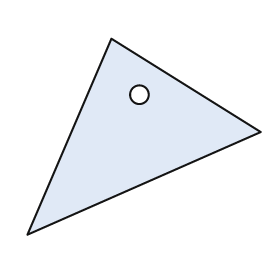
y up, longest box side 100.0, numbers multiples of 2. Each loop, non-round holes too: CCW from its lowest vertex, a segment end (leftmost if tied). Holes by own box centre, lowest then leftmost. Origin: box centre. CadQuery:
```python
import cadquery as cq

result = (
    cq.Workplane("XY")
    .moveTo(-50.0, -42.0)
    .lineTo(50.0, 2.0)
    .lineTo(-14.0, 42.0)
    .close()
    .moveTo(-2.0, 18.0)
    .circle(4.0)
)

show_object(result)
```